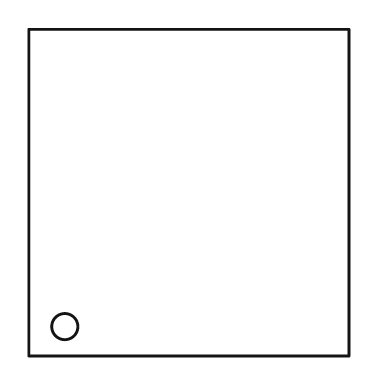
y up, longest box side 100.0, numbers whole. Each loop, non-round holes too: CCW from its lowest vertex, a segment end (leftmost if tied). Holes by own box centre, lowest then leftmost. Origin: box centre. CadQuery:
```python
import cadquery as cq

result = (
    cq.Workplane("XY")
    .moveTo(-49.0, -50.0)
    .lineTo(49.0, -50.0)
    .lineTo(49.0, 50.0)
    .lineTo(-49.0, 50.0)
    .close()
    .moveTo(-38.0, -41.0)
    .circle(4.0)
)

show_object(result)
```